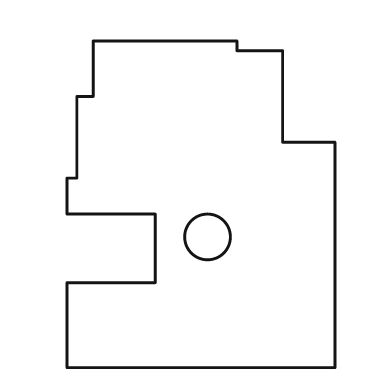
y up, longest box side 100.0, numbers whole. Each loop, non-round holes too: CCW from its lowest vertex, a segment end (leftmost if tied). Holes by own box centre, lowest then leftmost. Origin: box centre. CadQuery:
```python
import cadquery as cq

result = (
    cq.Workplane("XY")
    .moveTo(-41.0, -50.0)
    .lineTo(41.0, -50.0)
    .lineTo(41.0, 19.0)
    .lineTo(25.0, 19.0)
    .lineTo(25.0, 47.0)
    .lineTo(11.0, 47.0)
    .lineTo(11.0, 50.0)
    .lineTo(-33.0, 50.0)
    .lineTo(-33.0, 33.0)
    .lineTo(-38.0, 33.0)
    .lineTo(-38.0, 8.0)
    .lineTo(-41.0, 8.0)
    .lineTo(-41.0, -3.0)
    .lineTo(-14.0, -3.0)
    .lineTo(-14.0, -24.0)
    .lineTo(-41.0, -24.0)
    .close()
    .moveTo(2.0, -10.0)
    .circle(7.0)
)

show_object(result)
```